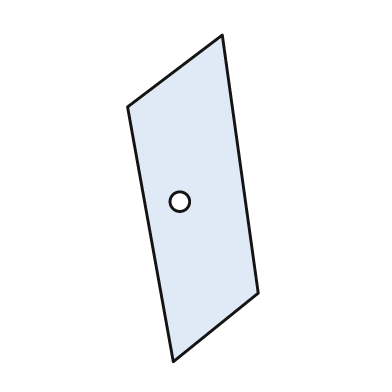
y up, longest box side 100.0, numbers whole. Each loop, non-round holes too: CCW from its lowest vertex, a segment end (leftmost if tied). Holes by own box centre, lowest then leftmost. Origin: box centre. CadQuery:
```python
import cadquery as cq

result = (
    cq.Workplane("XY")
    .moveTo(-6.0, -50.0)
    .lineTo(20.0, -29.0)
    .lineTo(9.0, 50.0)
    .lineTo(-20.0, 28.0)
    .close()
    .moveTo(-4.0, -1.0)
    .circle(3.0)
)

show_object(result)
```